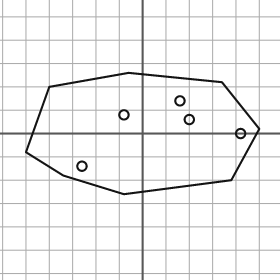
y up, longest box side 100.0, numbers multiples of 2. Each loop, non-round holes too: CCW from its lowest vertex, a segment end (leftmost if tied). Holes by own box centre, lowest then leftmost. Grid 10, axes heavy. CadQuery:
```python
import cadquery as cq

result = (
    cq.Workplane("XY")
    .moveTo(-8.0, -26.0)
    .lineTo(38.0, -20.0)
    .lineTo(50.0, 2.0)
    .lineTo(34.0, 22.0)
    .lineTo(-6.0, 26.0)
    .lineTo(-40.0, 20.0)
    .lineTo(-50.0, -8.0)
    .lineTo(-34.0, -18.0)
    .close()
    .moveTo(-26.0, -14.0)
    .circle(2.0)
    .moveTo(42.0, 0.0)
    .circle(2.0)
    .moveTo(20.0, 6.0)
    .circle(2.0)
    .moveTo(-8.0, 8.0)
    .circle(2.0)
    .moveTo(16.0, 14.0)
    .circle(2.0)
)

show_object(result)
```